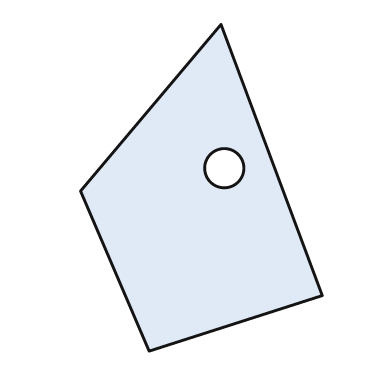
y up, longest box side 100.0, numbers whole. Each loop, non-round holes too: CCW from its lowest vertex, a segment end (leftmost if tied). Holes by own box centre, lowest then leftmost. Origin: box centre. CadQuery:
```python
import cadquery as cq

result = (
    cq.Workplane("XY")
    .moveTo(-16.0, -50.0)
    .lineTo(37.0, -33.0)
    .lineTo(6.0, 50.0)
    .lineTo(-37.0, -1.0)
    .close()
    .moveTo(7.0, 6.0)
    .circle(6.0)
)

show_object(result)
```